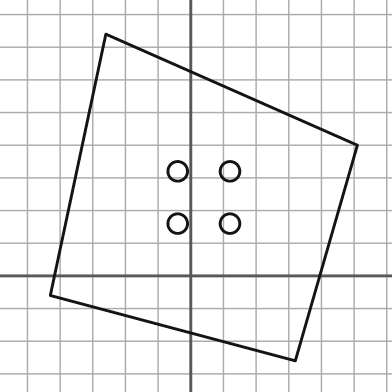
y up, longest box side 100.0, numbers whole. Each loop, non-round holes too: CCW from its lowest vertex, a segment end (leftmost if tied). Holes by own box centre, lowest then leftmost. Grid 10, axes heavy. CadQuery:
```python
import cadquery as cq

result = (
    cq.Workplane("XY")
    .moveTo(32.0, -26.0)
    .lineTo(51.0, 40.0)
    .lineTo(-26.0, 74.0)
    .lineTo(-43.0, -6.0)
    .close()
    .moveTo(-4.0, 16.0)
    .circle(3.0)
    .moveTo(12.0, 16.0)
    .circle(3.0)
    .moveTo(-4.0, 32.0)
    .circle(3.0)
    .moveTo(12.0, 32.0)
    .circle(3.0)
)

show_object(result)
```